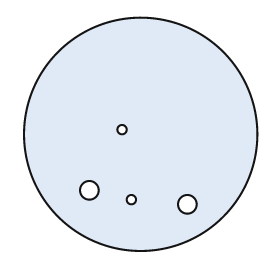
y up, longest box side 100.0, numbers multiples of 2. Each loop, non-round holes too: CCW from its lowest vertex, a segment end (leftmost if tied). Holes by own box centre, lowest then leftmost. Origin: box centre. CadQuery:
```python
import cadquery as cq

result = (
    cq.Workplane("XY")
    .moveTo(0.0, 0.0)
    .circle(50.0)
    .moveTo(20.0, -30.0)
    .circle(4.0)
    .moveTo(-4.0, -28.0)
    .circle(2.0)
    .moveTo(-22.0, -24.0)
    .circle(4.0)
    .moveTo(-8.0, 2.0)
    .circle(2.0)
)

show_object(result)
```